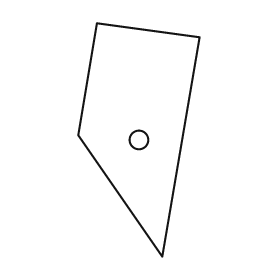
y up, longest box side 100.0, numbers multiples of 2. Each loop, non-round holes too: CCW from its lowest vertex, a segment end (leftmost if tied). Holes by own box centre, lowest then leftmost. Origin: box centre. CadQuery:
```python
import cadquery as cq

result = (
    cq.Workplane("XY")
    .moveTo(10.0, -50.0)
    .lineTo(26.0, 44.0)
    .lineTo(-18.0, 50.0)
    .lineTo(-26.0, 2.0)
    .close()
    .moveTo(0.0, 0.0)
    .circle(4.0)
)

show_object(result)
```